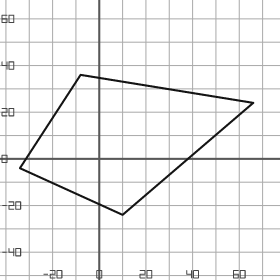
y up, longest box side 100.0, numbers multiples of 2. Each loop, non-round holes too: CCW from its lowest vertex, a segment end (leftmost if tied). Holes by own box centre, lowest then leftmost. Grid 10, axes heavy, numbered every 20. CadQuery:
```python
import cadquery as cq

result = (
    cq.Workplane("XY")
    .moveTo(10.0, -24.0)
    .lineTo(66.0, 24.0)
    .lineTo(-8.0, 36.0)
    .lineTo(-34.0, -4.0)
    .close()
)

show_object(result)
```